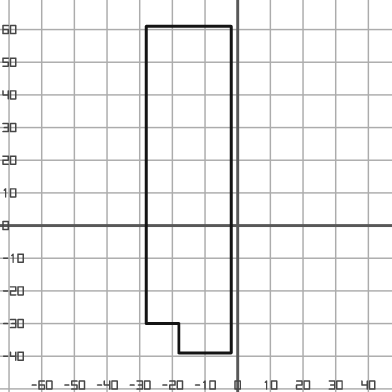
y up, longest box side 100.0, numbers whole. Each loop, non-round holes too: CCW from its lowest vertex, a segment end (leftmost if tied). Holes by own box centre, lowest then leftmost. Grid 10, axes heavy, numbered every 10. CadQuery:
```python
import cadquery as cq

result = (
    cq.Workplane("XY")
    .moveTo(-18.0, -39.0)
    .lineTo(-2.0, -39.0)
    .lineTo(-2.0, 61.0)
    .lineTo(-28.0, 61.0)
    .lineTo(-28.0, -30.0)
    .lineTo(-18.0, -30.0)
    .close()
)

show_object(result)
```